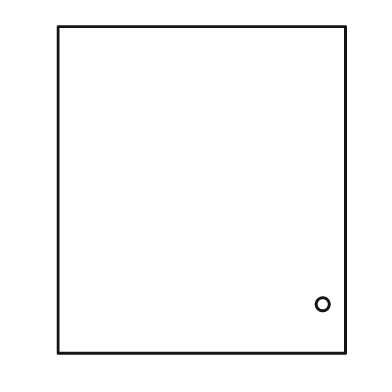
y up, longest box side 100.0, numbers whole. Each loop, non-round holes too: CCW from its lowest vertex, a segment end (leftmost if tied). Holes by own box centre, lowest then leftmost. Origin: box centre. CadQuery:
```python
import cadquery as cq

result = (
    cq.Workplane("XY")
    .moveTo(-44.0, -50.0)
    .lineTo(44.0, -50.0)
    .lineTo(44.0, 50.0)
    .lineTo(-44.0, 50.0)
    .close()
    .moveTo(37.0, -35.0)
    .circle(2.0)
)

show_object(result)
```